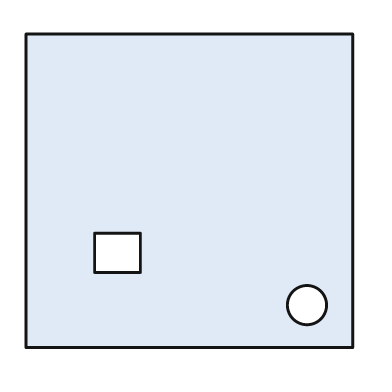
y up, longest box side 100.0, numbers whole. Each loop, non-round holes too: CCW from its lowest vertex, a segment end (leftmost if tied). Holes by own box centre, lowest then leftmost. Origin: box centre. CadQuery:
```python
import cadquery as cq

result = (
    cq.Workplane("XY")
    .moveTo(-50.0, -48.0)
    .lineTo(50.0, -48.0)
    .lineTo(50.0, 48.0)
    .lineTo(-50.0, 48.0)
    .close()
    .moveTo(36.0, -35.0)
    .circle(6.0)
    .moveTo(-29.0, -25.0)
    .lineTo(-15.0, -25.0)
    .lineTo(-15.0, -13.0)
    .lineTo(-29.0, -13.0)
    .close()
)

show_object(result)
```